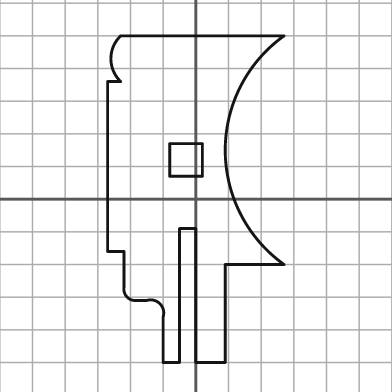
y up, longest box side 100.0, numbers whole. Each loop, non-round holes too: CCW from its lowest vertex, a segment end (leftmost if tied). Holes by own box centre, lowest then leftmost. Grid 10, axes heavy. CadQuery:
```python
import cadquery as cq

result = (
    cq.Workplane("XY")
    .moveTo(-10.0, -50.0)
    .lineTo(-5.0, -50.0)
    .lineTo(-5.0, -9.0)
    .lineTo(0.0, -9.0)
    .lineTo(0.0, -50.0)
    .lineTo(9.0, -50.0)
    .lineTo(9.0, -20.0)
    .lineTo(27.0, -20.0)
    .threePointArc((9.0, 15.0), (27.0, 50.0))
    .lineTo(-23.0, 50.0)
    .threePointArc((-26.0, 43.0), (-23.0, 36.0))
    .lineTo(-27.0, 36.0)
    .lineTo(-27.0, -16.0)
    .lineTo(-22.0, -16.0)
    .lineTo(-22.0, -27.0)
    .threePointArc((-21.0, -30.0), (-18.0, -31.0))
    .lineTo(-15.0, -31.0)
    .threePointArc((-11.0, -32.0), (-10.0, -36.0))
    .close()
    .moveTo(-8.0, 7.0)
    .lineTo(2.0, 7.0)
    .lineTo(2.0, 17.0)
    .lineTo(-8.0, 17.0)
    .close()
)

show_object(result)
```